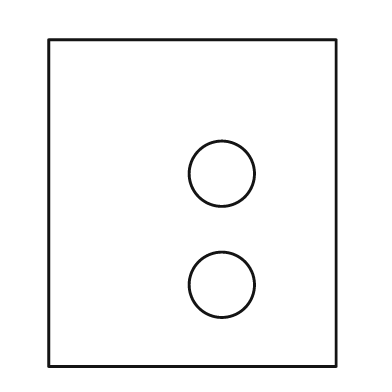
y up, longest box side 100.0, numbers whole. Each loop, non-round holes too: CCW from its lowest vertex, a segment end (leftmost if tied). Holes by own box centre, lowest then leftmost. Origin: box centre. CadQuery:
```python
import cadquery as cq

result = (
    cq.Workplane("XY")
    .moveTo(-44.0, -50.0)
    .lineTo(44.0, -50.0)
    .lineTo(44.0, 50.0)
    .lineTo(-44.0, 50.0)
    .close()
    .moveTo(9.0, -25.0)
    .circle(10.0)
    .moveTo(9.0, 9.0)
    .circle(10.0)
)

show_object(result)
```